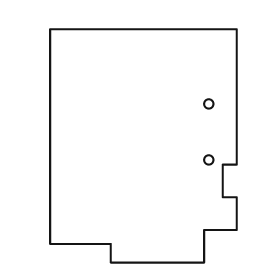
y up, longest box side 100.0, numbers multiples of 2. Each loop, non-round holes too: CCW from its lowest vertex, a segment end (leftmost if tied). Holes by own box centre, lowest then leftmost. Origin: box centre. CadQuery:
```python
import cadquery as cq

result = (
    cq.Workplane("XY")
    .moveTo(-14.0, -50.0)
    .lineTo(26.0, -50.0)
    .lineTo(26.0, -36.0)
    .lineTo(40.0, -36.0)
    .lineTo(40.0, -22.0)
    .lineTo(34.0, -22.0)
    .lineTo(34.0, -8.0)
    .lineTo(40.0, -8.0)
    .lineTo(40.0, 50.0)
    .lineTo(-40.0, 50.0)
    .lineTo(-40.0, -42.0)
    .lineTo(-14.0, -42.0)
    .close()
    .moveTo(28.0, -6.0)
    .circle(2.0)
    .moveTo(28.0, 18.0)
    .circle(2.0)
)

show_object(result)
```